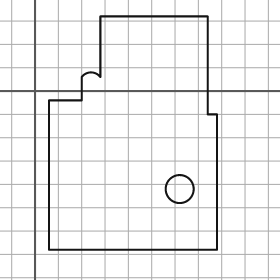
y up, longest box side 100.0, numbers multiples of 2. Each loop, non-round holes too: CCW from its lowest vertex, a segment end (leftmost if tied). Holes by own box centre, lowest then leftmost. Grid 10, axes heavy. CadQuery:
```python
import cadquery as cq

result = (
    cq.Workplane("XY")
    .moveTo(6.0, -68.0)
    .lineTo(78.0, -68.0)
    .lineTo(78.0, -10.0)
    .lineTo(74.0, -10.0)
    .lineTo(74.0, 32.0)
    .lineTo(28.0, 32.0)
    .lineTo(28.0, 6.0)
    .threePointArc((24.0, 8.0), (20.0, 6.0))
    .lineTo(20.0, -4.0)
    .lineTo(6.0, -4.0)
    .close()
    .moveTo(62.0, -42.0)
    .circle(6.0)
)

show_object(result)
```